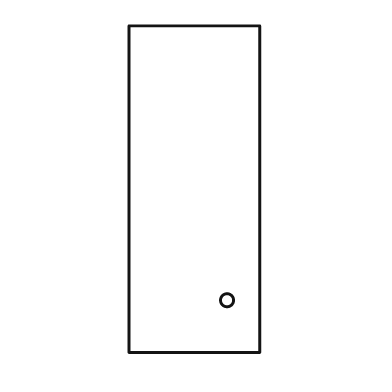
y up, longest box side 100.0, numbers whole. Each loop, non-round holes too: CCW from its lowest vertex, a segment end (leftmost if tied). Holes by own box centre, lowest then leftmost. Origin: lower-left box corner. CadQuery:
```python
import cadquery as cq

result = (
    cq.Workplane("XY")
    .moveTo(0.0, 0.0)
    .lineTo(40.0, 0.0)
    .lineTo(40.0, 100.0)
    .lineTo(0.0, 100.0)
    .close()
    .moveTo(30.0, 16.0)
    .circle(2.0)
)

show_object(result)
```